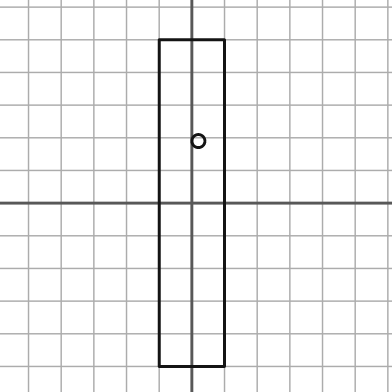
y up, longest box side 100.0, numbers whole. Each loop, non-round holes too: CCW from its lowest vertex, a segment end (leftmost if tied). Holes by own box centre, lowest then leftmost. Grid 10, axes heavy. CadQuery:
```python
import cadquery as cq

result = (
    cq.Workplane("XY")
    .moveTo(-10.0, -50.0)
    .lineTo(10.0, -50.0)
    .lineTo(10.0, 50.0)
    .lineTo(-10.0, 50.0)
    .close()
    .moveTo(2.0, 19.0)
    .circle(2.0)
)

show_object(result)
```